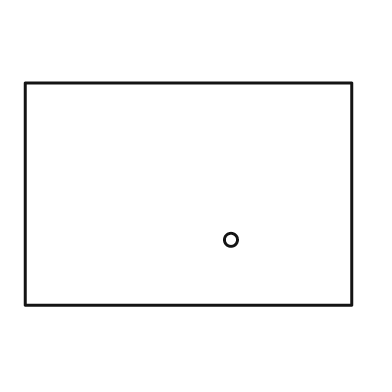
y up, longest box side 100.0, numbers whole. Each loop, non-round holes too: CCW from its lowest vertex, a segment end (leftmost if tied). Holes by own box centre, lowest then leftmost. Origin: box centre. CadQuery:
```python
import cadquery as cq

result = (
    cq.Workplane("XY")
    .moveTo(-50.0, -34.0)
    .lineTo(50.0, -34.0)
    .lineTo(50.0, 34.0)
    .lineTo(-50.0, 34.0)
    .close()
    .moveTo(13.0, -14.0)
    .circle(2.0)
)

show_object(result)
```